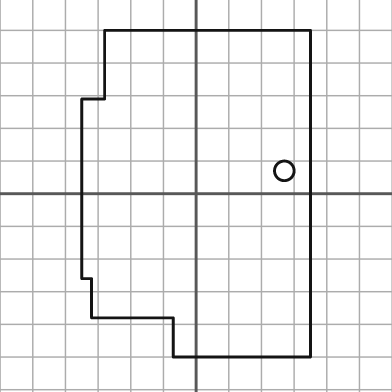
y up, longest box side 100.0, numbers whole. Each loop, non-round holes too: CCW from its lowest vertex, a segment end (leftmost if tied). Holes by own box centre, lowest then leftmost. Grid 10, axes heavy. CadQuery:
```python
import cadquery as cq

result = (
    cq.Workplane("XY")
    .moveTo(-7.0, -50.0)
    .lineTo(35.0, -50.0)
    .lineTo(35.0, 50.0)
    .lineTo(-28.0, 50.0)
    .lineTo(-28.0, 29.0)
    .lineTo(-35.0, 29.0)
    .lineTo(-35.0, -26.0)
    .lineTo(-32.0, -26.0)
    .lineTo(-32.0, -38.0)
    .lineTo(-7.0, -38.0)
    .close()
    .moveTo(27.0, 7.0)
    .circle(3.0)
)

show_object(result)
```